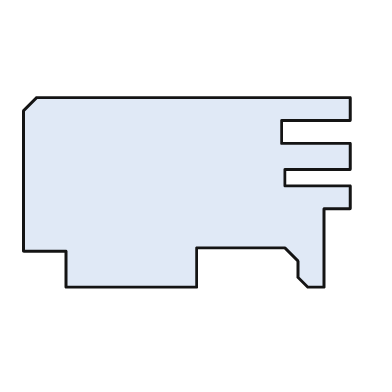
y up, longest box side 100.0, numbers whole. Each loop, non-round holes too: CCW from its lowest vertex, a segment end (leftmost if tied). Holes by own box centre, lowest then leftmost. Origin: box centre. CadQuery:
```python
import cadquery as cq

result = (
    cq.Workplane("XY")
    .moveTo(-37.0, -29.0)
    .lineTo(3.0, -29.0)
    .lineTo(3.0, -17.0)
    .lineTo(30.0, -17.0)
    .lineTo(34.0, -21.0)
    .lineTo(34.0, -26.0)
    .lineTo(37.0, -29.0)
    .lineTo(42.0, -29.0)
    .lineTo(42.0, -5.0)
    .lineTo(50.0, -5.0)
    .lineTo(50.0, 2.0)
    .lineTo(30.0, 2.0)
    .lineTo(30.0, 7.0)
    .lineTo(50.0, 7.0)
    .lineTo(50.0, 15.0)
    .lineTo(29.0, 15.0)
    .lineTo(29.0, 22.0)
    .lineTo(50.0, 22.0)
    .lineTo(50.0, 29.0)
    .lineTo(-46.0, 29.0)
    .lineTo(-50.0, 25.0)
    .lineTo(-50.0, -18.0)
    .lineTo(-37.0, -18.0)
    .close()
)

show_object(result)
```